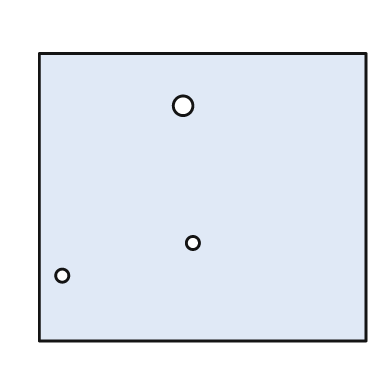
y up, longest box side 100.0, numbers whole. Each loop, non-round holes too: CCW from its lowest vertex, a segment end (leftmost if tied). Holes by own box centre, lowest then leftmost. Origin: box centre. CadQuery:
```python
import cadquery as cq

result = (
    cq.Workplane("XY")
    .moveTo(-50.0, -44.0)
    .lineTo(50.0, -44.0)
    .lineTo(50.0, 44.0)
    .lineTo(-50.0, 44.0)
    .close()
    .moveTo(-43.0, -24.0)
    .circle(2.0)
    .moveTo(-3.0, -14.0)
    .circle(2.0)
    .moveTo(-6.0, 28.0)
    .circle(3.0)
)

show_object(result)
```